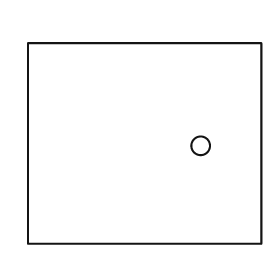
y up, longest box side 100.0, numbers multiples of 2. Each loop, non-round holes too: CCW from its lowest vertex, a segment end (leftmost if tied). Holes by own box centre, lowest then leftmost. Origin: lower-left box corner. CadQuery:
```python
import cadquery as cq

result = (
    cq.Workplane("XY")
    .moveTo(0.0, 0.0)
    .lineTo(100.0, 0.0)
    .lineTo(100.0, 86.0)
    .lineTo(0.0, 86.0)
    .close()
    .moveTo(74.0, 42.0)
    .circle(4.0)
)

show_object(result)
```